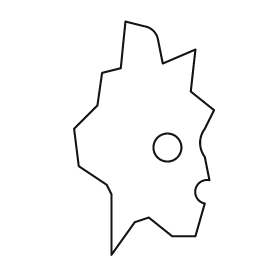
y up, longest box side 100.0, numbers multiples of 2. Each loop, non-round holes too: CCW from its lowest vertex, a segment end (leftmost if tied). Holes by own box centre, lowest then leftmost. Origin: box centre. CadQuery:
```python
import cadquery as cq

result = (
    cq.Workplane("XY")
    .moveTo(-14.0, -50.0)
    .lineTo(-4.0, -36.0)
    .lineTo(2.0, -34.0)
    .lineTo(12.0, -42.0)
    .lineTo(22.0, -42.0)
    .lineTo(26.0, -28.0)
    .threePointArc((22.0, -22.0), (28.0, -18.0))
    .lineTo(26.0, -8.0)
    .threePointArc((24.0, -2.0), (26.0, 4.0))
    .lineTo(30.0, 12.0)
    .lineTo(20.0, 20.0)
    .lineTo(22.0, 38.0)
    .lineTo(8.0, 32.0)
    .lineTo(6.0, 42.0)
    .threePointArc((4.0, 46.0), (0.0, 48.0))
    .lineTo(-8.0, 50.0)
    .lineTo(-10.0, 30.0)
    .lineTo(-18.0, 28.0)
    .lineTo(-20.0, 14.0)
    .lineTo(-30.0, 4.0)
    .lineTo(-28.0, -12.0)
    .lineTo(-16.0, -20.0)
    .lineTo(-14.0, -24.0)
    .close()
    .moveTo(10.0, -4.0)
    .circle(6.0)
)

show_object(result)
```